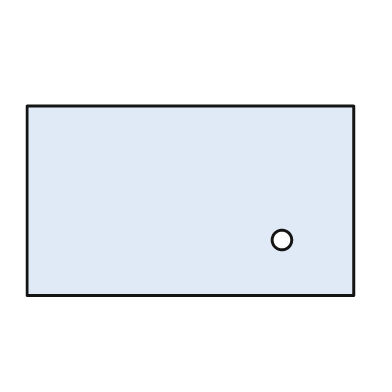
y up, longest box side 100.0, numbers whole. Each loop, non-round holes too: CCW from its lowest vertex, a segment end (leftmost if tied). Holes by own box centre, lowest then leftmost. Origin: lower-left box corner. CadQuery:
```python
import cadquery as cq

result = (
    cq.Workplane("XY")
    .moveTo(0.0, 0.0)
    .lineTo(100.0, 0.0)
    .lineTo(100.0, 58.0)
    .lineTo(0.0, 58.0)
    .close()
    .moveTo(78.0, 17.0)
    .circle(3.0)
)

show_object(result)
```